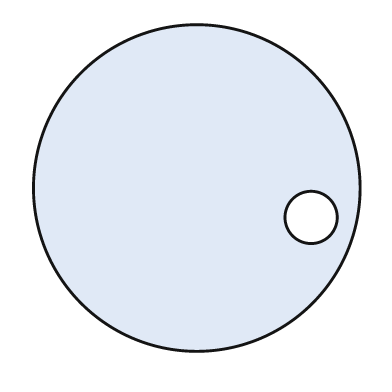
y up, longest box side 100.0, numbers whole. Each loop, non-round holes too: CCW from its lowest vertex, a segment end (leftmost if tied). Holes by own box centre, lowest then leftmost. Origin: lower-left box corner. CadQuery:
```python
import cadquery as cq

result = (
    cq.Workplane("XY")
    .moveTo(50.0, 50.0)
    .circle(50.0)
    .moveTo(85.0, 41.0)
    .circle(8.0)
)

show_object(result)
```